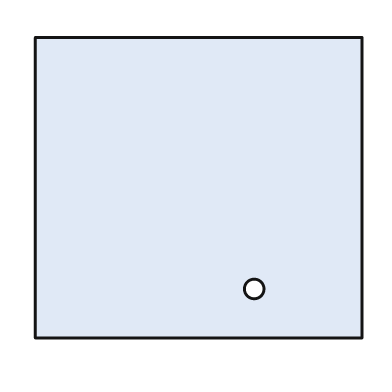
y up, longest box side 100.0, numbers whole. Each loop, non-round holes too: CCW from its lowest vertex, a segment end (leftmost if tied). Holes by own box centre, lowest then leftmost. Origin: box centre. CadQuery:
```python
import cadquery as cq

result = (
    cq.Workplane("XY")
    .moveTo(-50.0, -46.0)
    .lineTo(50.0, -46.0)
    .lineTo(50.0, 46.0)
    .lineTo(-50.0, 46.0)
    .close()
    .moveTo(17.0, -31.0)
    .circle(3.0)
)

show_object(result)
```